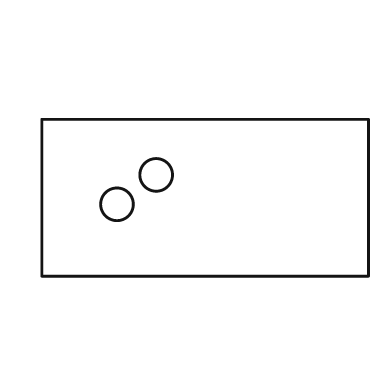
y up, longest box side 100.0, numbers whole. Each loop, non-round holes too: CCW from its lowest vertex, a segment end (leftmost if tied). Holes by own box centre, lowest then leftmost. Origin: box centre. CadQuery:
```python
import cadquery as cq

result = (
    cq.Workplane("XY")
    .moveTo(-50.0, -24.0)
    .lineTo(50.0, -24.0)
    .lineTo(50.0, 24.0)
    .lineTo(-50.0, 24.0)
    .close()
    .moveTo(-27.0, -2.0)
    .circle(5.0)
    .moveTo(-15.0, 7.0)
    .circle(5.0)
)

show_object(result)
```